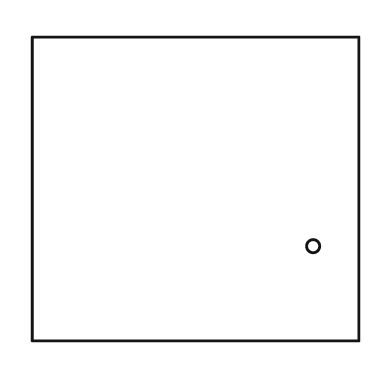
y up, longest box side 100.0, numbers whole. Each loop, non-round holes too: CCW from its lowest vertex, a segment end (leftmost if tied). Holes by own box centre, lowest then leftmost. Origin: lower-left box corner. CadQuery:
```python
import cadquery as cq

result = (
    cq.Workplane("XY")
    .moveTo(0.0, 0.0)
    .lineTo(100.0, 0.0)
    .lineTo(100.0, 93.0)
    .lineTo(0.0, 93.0)
    .close()
    .moveTo(86.0, 29.0)
    .circle(2.0)
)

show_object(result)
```